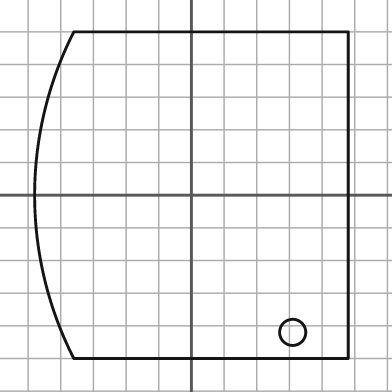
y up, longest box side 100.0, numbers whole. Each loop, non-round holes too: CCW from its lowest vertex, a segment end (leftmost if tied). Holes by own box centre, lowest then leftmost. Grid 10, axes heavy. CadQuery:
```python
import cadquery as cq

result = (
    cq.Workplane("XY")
    .moveTo(-36.0, -50.0)
    .lineTo(48.0, -50.0)
    .lineTo(48.0, 50.0)
    .lineTo(-36.0, 50.0)
    .threePointArc((-48.0, 0.0), (-36.0, -50.0))
    .close()
    .moveTo(31.0, -42.0)
    .circle(4.0)
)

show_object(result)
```